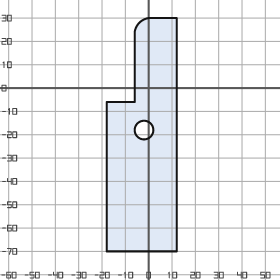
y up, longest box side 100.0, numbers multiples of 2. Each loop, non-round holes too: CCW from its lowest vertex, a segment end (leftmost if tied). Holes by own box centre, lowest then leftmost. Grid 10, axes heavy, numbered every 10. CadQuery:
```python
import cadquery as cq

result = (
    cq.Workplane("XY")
    .moveTo(-18.0, -70.0)
    .lineTo(12.0, -70.0)
    .lineTo(12.0, 30.0)
    .lineTo(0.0, 30.0)
    .threePointArc((-4.0, 28.0), (-6.0, 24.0))
    .lineTo(-6.0, -6.0)
    .lineTo(-18.0, -6.0)
    .close()
    .moveTo(-2.0, -18.0)
    .circle(4.0)
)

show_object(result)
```